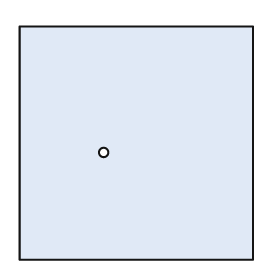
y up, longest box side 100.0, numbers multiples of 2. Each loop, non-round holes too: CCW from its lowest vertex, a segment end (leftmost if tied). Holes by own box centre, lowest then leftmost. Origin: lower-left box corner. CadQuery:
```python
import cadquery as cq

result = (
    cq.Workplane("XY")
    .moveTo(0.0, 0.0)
    .lineTo(100.0, 0.0)
    .lineTo(100.0, 100.0)
    .lineTo(0.0, 100.0)
    .close()
    .moveTo(36.0, 46.0)
    .circle(2.0)
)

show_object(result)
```